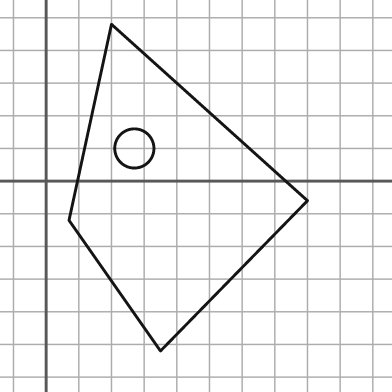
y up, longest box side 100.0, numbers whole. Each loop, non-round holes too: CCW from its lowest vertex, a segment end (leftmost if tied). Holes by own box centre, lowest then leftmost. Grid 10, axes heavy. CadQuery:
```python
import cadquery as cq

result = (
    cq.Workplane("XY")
    .moveTo(35.0, -52.0)
    .lineTo(80.0, -6.0)
    .lineTo(20.0, 48.0)
    .lineTo(7.0, -12.0)
    .close()
    .moveTo(27.0, 10.0)
    .circle(6.0)
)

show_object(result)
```